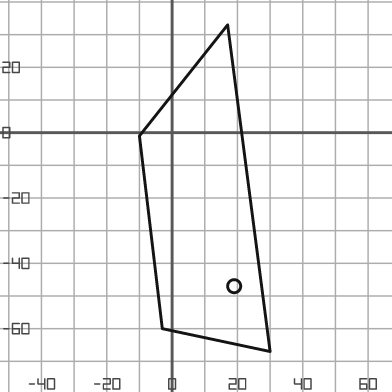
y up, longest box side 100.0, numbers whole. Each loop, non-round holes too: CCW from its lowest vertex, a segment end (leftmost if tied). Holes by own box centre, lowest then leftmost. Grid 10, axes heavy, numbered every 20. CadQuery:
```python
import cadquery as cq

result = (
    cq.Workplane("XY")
    .moveTo(30.0, -67.0)
    .lineTo(17.0, 33.0)
    .lineTo(-10.0, -1.0)
    .lineTo(-3.0, -60.0)
    .close()
    .moveTo(19.0, -47.0)
    .circle(2.0)
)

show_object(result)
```